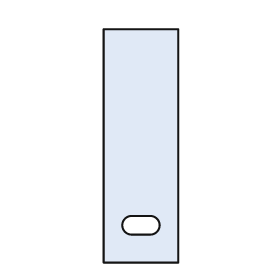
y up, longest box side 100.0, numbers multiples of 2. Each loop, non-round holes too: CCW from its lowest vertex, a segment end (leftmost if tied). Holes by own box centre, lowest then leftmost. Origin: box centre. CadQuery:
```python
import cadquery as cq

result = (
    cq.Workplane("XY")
    .moveTo(-16.0, -50.0)
    .lineTo(16.0, -50.0)
    .lineTo(16.0, 50.0)
    .lineTo(-16.0, 50.0)
    .close()
    .moveTo(-4.0, -38.0)
    .lineTo(4.0, -38.0)
    .threePointArc((8.0, -34.0), (4.0, -30.0))
    .lineTo(-4.0, -30.0)
    .threePointArc((-8.0, -34.0), (-4.0, -38.0))
    .close()
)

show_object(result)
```